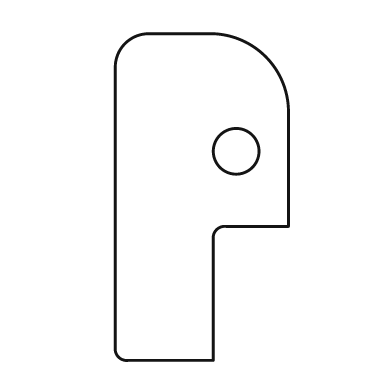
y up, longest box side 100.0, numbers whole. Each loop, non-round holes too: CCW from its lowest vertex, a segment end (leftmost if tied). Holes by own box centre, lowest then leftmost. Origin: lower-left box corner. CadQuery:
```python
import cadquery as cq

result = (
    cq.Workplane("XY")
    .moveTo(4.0, 0.0)
    .lineTo(30.0, 0.0)
    .lineTo(30.0, 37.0)
    .threePointArc((31.0, 40.0), (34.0, 41.0))
    .lineTo(53.0, 41.0)
    .lineTo(53.0, 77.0)
    .threePointArc((46.0, 93.0), (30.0, 100.0))
    .lineTo(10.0, 100.0)
    .threePointArc((3.0, 97.0), (0.0, 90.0))
    .lineTo(0.0, 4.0)
    .threePointArc((1.0, 1.0), (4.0, 0.0))
    .close()
    .moveTo(37.0, 64.0)
    .circle(7.0)
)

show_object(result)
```